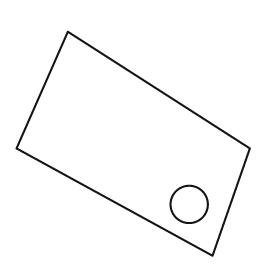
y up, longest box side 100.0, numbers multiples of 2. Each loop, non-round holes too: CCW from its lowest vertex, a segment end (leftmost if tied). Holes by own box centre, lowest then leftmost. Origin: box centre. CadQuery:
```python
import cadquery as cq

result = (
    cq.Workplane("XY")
    .moveTo(34.0, -48.0)
    .lineTo(50.0, -2.0)
    .lineTo(-28.0, 48.0)
    .lineTo(-50.0, -2.0)
    .close()
    .moveTo(24.0, -26.0)
    .circle(8.0)
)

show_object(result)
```